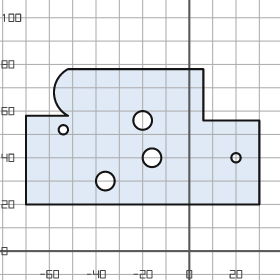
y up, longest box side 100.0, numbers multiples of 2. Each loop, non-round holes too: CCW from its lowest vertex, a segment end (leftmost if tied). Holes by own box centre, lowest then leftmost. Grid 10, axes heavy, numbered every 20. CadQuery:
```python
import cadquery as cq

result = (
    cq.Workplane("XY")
    .moveTo(-70.0, 20.0)
    .lineTo(30.0, 20.0)
    .lineTo(30.0, 56.0)
    .lineTo(6.0, 56.0)
    .lineTo(6.0, 78.0)
    .lineTo(-52.0, 78.0)
    .threePointArc((-58.0, 68.0), (-52.0, 58.0))
    .lineTo(-70.0, 58.0)
    .close()
    .moveTo(-36.0, 30.0)
    .circle(4.0)
    .moveTo(-16.0, 40.0)
    .circle(4.0)
    .moveTo(20.0, 40.0)
    .circle(2.0)
    .moveTo(-54.0, 52.0)
    .circle(2.0)
    .moveTo(-20.0, 56.0)
    .circle(4.0)
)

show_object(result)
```